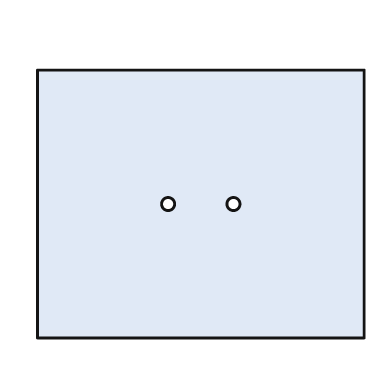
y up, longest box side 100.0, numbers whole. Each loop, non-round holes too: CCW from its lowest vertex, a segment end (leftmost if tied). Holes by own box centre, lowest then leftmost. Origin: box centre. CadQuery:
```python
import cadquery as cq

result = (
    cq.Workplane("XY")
    .moveTo(-50.0, -41.0)
    .lineTo(50.0, -41.0)
    .lineTo(50.0, 41.0)
    .lineTo(-50.0, 41.0)
    .close()
    .moveTo(-10.0, 0.0)
    .circle(2.0)
    .moveTo(10.0, 0.0)
    .circle(2.0)
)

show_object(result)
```